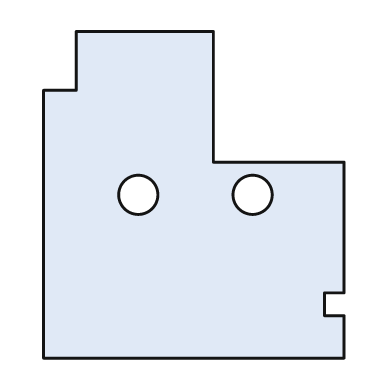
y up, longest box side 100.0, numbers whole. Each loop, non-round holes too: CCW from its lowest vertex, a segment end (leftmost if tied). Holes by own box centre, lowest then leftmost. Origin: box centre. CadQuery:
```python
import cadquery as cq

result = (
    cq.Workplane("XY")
    .moveTo(-46.0, -50.0)
    .lineTo(46.0, -50.0)
    .lineTo(46.0, -37.0)
    .lineTo(40.0, -37.0)
    .lineTo(40.0, -30.0)
    .lineTo(46.0, -30.0)
    .lineTo(46.0, 10.0)
    .lineTo(6.0, 10.0)
    .lineTo(6.0, 50.0)
    .lineTo(-36.0, 50.0)
    .lineTo(-36.0, 32.0)
    .lineTo(-46.0, 32.0)
    .close()
    .moveTo(-17.0, 0.0)
    .circle(6.0)
    .moveTo(18.0, 0.0)
    .circle(6.0)
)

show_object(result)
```